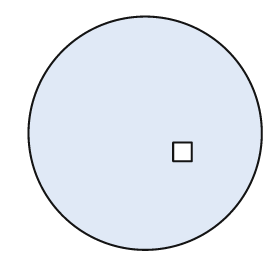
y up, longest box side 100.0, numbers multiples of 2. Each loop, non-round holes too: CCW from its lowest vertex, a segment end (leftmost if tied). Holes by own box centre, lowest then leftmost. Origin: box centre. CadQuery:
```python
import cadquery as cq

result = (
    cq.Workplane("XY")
    .moveTo(0.0, 0.0)
    .circle(50.0)
    .moveTo(12.0, -12.0)
    .lineTo(20.0, -12.0)
    .lineTo(20.0, -4.0)
    .lineTo(12.0, -4.0)
    .close()
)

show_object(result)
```